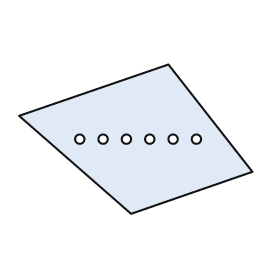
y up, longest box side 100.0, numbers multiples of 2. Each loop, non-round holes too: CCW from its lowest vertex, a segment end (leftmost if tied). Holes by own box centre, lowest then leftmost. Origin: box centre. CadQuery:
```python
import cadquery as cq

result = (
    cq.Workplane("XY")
    .moveTo(-2.0, -32.0)
    .lineTo(50.0, -14.0)
    .lineTo(14.0, 32.0)
    .lineTo(-50.0, 10.0)
    .close()
    .moveTo(-24.0, 0.0)
    .circle(2.0)
    .moveTo(-14.0, 0.0)
    .circle(2.0)
    .moveTo(-4.0, 0.0)
    .circle(2.0)
    .moveTo(6.0, 0.0)
    .circle(2.0)
    .moveTo(16.0, 0.0)
    .circle(2.0)
    .moveTo(26.0, 0.0)
    .circle(2.0)
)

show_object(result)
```